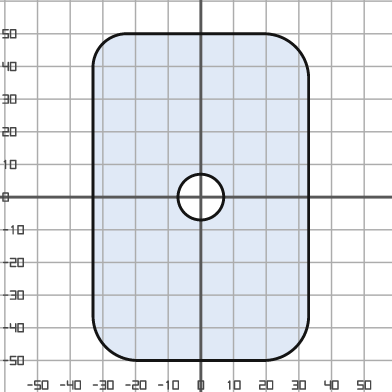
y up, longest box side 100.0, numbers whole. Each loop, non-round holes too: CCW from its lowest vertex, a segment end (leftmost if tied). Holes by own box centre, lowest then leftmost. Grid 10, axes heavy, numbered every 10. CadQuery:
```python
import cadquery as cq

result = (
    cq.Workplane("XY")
    .moveTo(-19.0, -50.0)
    .lineTo(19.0, -50.0)
    .threePointArc((29.0, -46.0), (33.0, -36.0))
    .lineTo(33.0, 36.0)
    .threePointArc((29.0, 46.0), (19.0, 50.0))
    .lineTo(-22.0, 50.0)
    .threePointArc((-30.0, 47.0), (-33.0, 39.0))
    .lineTo(-33.0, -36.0)
    .threePointArc((-29.0, -46.0), (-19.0, -50.0))
    .close()
    .moveTo(0.0, 0.0)
    .circle(7.0)
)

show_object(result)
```